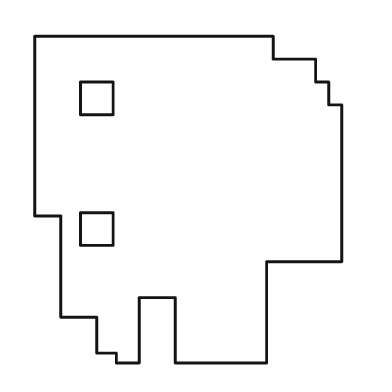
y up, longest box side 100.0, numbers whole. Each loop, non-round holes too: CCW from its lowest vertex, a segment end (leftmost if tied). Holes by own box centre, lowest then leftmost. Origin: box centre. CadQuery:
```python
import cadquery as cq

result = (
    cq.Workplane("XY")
    .moveTo(-22.0, -50.0)
    .lineTo(-15.0, -50.0)
    .lineTo(-15.0, -30.0)
    .lineTo(-4.0, -30.0)
    .lineTo(-4.0, -50.0)
    .lineTo(24.0, -50.0)
    .lineTo(24.0, -19.0)
    .lineTo(47.0, -19.0)
    .lineTo(47.0, 29.0)
    .lineTo(43.0, 29.0)
    .lineTo(43.0, 36.0)
    .lineTo(39.0, 36.0)
    .lineTo(39.0, 43.0)
    .lineTo(26.0, 43.0)
    .lineTo(26.0, 50.0)
    .lineTo(-47.0, 50.0)
    .lineTo(-47.0, -5.0)
    .lineTo(-39.0, -5.0)
    .lineTo(-39.0, -36.0)
    .lineTo(-28.0, -36.0)
    .lineTo(-28.0, -47.0)
    .lineTo(-22.0, -47.0)
    .close()
    .moveTo(-33.0, -14.0)
    .lineTo(-23.0, -14.0)
    .lineTo(-23.0, -4.0)
    .lineTo(-33.0, -4.0)
    .close()
    .moveTo(-33.0, 26.0)
    .lineTo(-23.0, 26.0)
    .lineTo(-23.0, 36.0)
    .lineTo(-33.0, 36.0)
    .close()
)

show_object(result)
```